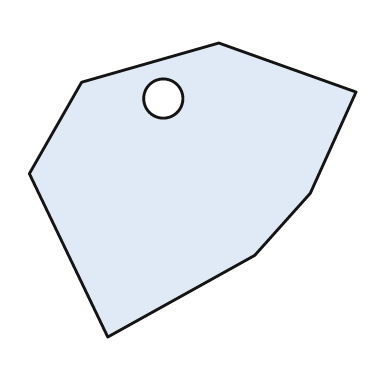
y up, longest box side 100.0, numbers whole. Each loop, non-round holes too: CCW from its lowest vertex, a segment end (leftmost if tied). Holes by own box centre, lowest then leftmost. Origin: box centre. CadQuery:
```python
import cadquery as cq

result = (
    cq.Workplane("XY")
    .moveTo(-26.0, -45.0)
    .lineTo(19.0, -20.0)
    .lineTo(36.0, -1.0)
    .lineTo(50.0, 30.0)
    .lineTo(8.0, 45.0)
    .lineTo(-34.0, 33.0)
    .lineTo(-50.0, 5.0)
    .close()
    .moveTo(-9.0, 28.0)
    .circle(6.0)
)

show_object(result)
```